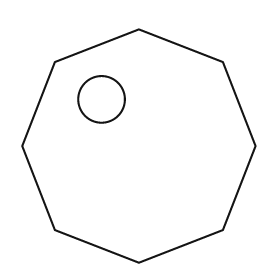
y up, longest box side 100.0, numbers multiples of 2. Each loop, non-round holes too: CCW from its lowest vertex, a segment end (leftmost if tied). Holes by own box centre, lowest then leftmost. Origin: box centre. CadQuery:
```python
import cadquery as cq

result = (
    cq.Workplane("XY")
    .moveTo(0.0, -50.0)
    .lineTo(36.0, -36.0)
    .lineTo(50.0, 0.0)
    .lineTo(36.0, 36.0)
    .lineTo(0.0, 50.0)
    .lineTo(-36.0, 36.0)
    .lineTo(-50.0, 0.0)
    .lineTo(-36.0, -36.0)
    .close()
    .moveTo(-16.0, 20.0)
    .circle(10.0)
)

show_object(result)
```